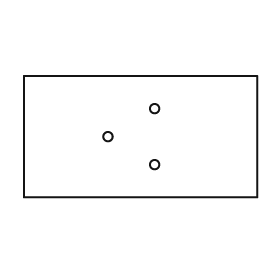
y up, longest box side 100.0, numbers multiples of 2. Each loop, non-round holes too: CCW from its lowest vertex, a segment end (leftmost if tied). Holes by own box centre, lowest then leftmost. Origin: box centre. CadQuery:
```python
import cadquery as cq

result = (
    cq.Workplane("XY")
    .moveTo(-50.0, -26.0)
    .lineTo(50.0, -26.0)
    .lineTo(50.0, 26.0)
    .lineTo(-50.0, 26.0)
    .close()
    .moveTo(6.0, -12.0)
    .circle(2.0)
    .moveTo(-14.0, 0.0)
    .circle(2.0)
    .moveTo(6.0, 12.0)
    .circle(2.0)
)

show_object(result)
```